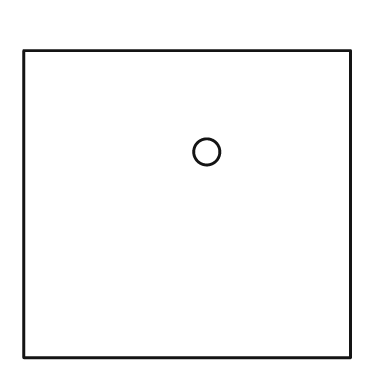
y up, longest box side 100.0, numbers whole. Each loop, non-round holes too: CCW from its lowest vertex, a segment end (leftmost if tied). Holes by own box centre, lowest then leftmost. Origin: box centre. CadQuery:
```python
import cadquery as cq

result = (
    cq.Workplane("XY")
    .moveTo(-50.0, -47.0)
    .lineTo(50.0, -47.0)
    .lineTo(50.0, 47.0)
    .lineTo(-50.0, 47.0)
    .close()
    .moveTo(6.0, 16.0)
    .circle(4.0)
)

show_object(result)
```